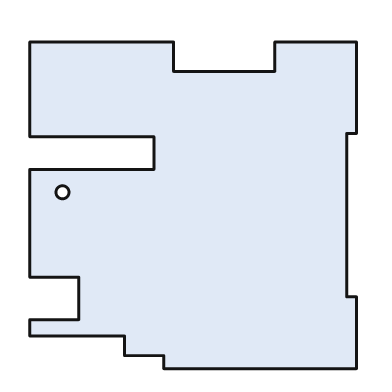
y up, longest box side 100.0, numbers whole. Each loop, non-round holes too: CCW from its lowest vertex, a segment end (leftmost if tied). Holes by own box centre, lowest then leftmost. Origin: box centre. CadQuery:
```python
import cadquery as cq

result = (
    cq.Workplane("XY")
    .moveTo(-9.0, -50.0)
    .lineTo(50.0, -50.0)
    .lineTo(50.0, -28.0)
    .lineTo(47.0, -28.0)
    .lineTo(47.0, 22.0)
    .lineTo(50.0, 22.0)
    .lineTo(50.0, 50.0)
    .lineTo(25.0, 50.0)
    .lineTo(25.0, 41.0)
    .lineTo(-6.0, 41.0)
    .lineTo(-6.0, 50.0)
    .lineTo(-50.0, 50.0)
    .lineTo(-50.0, 21.0)
    .lineTo(-12.0, 21.0)
    .lineTo(-12.0, 11.0)
    .lineTo(-50.0, 11.0)
    .lineTo(-50.0, -22.0)
    .lineTo(-35.0, -22.0)
    .lineTo(-35.0, -35.0)
    .lineTo(-50.0, -35.0)
    .lineTo(-50.0, -40.0)
    .lineTo(-21.0, -40.0)
    .lineTo(-21.0, -46.0)
    .lineTo(-9.0, -46.0)
    .close()
    .moveTo(-40.0, 4.0)
    .circle(2.0)
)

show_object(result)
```